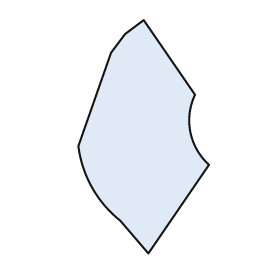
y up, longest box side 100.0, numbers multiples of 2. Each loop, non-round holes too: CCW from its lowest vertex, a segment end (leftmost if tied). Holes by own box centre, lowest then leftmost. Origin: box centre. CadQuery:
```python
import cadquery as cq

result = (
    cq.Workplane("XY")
    .moveTo(2.0, -50.0)
    .lineTo(28.0, -12.0)
    .threePointArc((20.0, 2.0), (22.0, 18.0))
    .lineTo(0.0, 50.0)
    .lineTo(-8.0, 44.0)
    .lineTo(-14.0, 36.0)
    .lineTo(-28.0, -4.0)
    .threePointArc((-22.0, -22.0), (-10.0, -36.0))
    .close()
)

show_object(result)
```